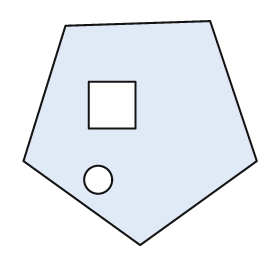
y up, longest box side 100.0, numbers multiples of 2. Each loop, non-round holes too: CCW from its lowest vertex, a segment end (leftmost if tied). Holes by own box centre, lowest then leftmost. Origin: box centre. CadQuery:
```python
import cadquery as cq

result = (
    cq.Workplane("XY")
    .moveTo(0.0, -48.0)
    .lineTo(50.0, -12.0)
    .lineTo(30.0, 48.0)
    .lineTo(-32.0, 46.0)
    .lineTo(-50.0, -12.0)
    .close()
    .moveTo(-18.0, -20.0)
    .circle(6.0)
    .moveTo(-22.0, 2.0)
    .lineTo(-2.0, 2.0)
    .lineTo(-2.0, 22.0)
    .lineTo(-22.0, 22.0)
    .close()
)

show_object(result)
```